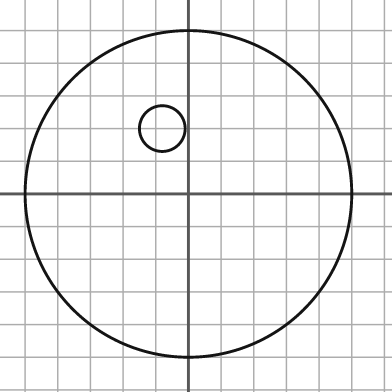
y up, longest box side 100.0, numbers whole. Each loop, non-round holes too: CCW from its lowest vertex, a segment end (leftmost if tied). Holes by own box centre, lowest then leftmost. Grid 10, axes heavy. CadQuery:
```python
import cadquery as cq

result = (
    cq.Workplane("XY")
    .moveTo(0.0, 0.0)
    .circle(50.0)
    .moveTo(-8.0, 20.0)
    .circle(7.0)
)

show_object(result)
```